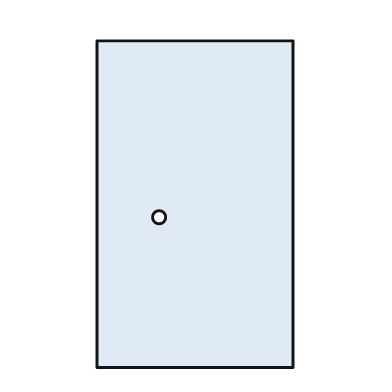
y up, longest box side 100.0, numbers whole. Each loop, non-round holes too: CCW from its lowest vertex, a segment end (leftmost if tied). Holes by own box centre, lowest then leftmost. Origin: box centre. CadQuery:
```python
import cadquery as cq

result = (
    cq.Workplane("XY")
    .moveTo(-30.0, -50.0)
    .lineTo(30.0, -50.0)
    .lineTo(30.0, 50.0)
    .lineTo(-30.0, 50.0)
    .close()
    .moveTo(-11.0, -4.0)
    .circle(2.0)
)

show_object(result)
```